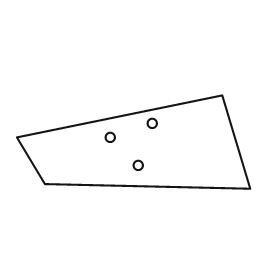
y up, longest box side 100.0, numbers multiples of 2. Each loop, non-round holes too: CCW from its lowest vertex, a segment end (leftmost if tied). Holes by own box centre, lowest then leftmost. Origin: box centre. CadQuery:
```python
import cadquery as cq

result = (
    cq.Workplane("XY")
    .moveTo(50.0, -20.0)
    .lineTo(38.0, 20.0)
    .lineTo(-50.0, 2.0)
    .lineTo(-38.0, -18.0)
    .close()
    .moveTo(2.0, -10.0)
    .circle(2.0)
    .moveTo(-10.0, 2.0)
    .circle(2.0)
    .moveTo(8.0, 8.0)
    .circle(2.0)
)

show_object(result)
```